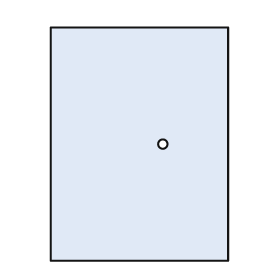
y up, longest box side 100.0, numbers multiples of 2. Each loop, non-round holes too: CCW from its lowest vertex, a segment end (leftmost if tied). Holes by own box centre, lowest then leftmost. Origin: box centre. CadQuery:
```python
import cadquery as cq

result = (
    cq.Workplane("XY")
    .moveTo(-38.0, -50.0)
    .lineTo(38.0, -50.0)
    .lineTo(38.0, 50.0)
    .lineTo(-38.0, 50.0)
    .close()
    .moveTo(10.0, 0.0)
    .circle(2.0)
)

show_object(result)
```